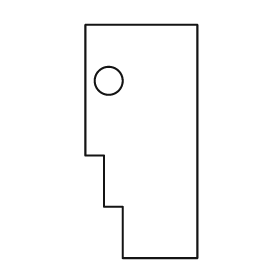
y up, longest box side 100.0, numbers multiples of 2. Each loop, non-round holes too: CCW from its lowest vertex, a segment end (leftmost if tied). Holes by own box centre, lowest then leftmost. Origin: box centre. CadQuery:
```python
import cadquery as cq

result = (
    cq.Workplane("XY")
    .moveTo(-8.0, -50.0)
    .lineTo(24.0, -50.0)
    .lineTo(24.0, 50.0)
    .lineTo(-24.0, 50.0)
    .lineTo(-24.0, -6.0)
    .lineTo(-16.0, -6.0)
    .lineTo(-16.0, -28.0)
    .lineTo(-8.0, -28.0)
    .close()
    .moveTo(-14.0, 26.0)
    .circle(6.0)
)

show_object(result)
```